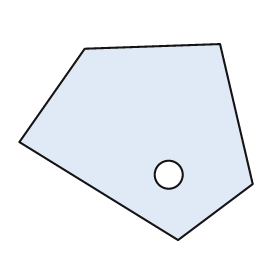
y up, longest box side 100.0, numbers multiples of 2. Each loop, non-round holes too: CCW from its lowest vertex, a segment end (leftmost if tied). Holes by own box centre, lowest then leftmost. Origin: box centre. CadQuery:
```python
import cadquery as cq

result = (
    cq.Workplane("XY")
    .moveTo(18.0, -42.0)
    .lineTo(50.0, -18.0)
    .lineTo(36.0, 42.0)
    .lineTo(-22.0, 40.0)
    .lineTo(-50.0, 0.0)
    .close()
    .moveTo(14.0, -14.0)
    .circle(6.0)
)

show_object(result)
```